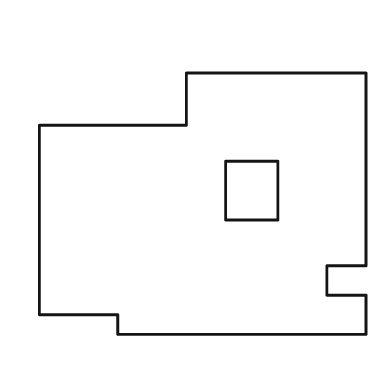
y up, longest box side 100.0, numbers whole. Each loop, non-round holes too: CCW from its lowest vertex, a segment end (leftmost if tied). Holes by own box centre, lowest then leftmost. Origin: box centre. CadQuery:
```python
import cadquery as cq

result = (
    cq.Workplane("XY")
    .moveTo(-26.0, -40.0)
    .lineTo(50.0, -40.0)
    .lineTo(50.0, -28.0)
    .lineTo(38.0, -28.0)
    .lineTo(38.0, -19.0)
    .lineTo(50.0, -19.0)
    .lineTo(50.0, 40.0)
    .lineTo(-5.0, 40.0)
    .lineTo(-5.0, 24.0)
    .lineTo(-50.0, 24.0)
    .lineTo(-50.0, -34.0)
    .lineTo(-26.0, -34.0)
    .close()
    .moveTo(7.0, -5.0)
    .lineTo(23.0, -5.0)
    .lineTo(23.0, 13.0)
    .lineTo(7.0, 13.0)
    .close()
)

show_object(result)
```